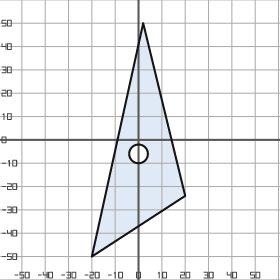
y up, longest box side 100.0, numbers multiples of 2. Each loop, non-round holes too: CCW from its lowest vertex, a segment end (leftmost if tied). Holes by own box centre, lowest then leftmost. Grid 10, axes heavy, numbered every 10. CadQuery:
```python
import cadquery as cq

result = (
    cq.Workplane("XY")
    .moveTo(-20.0, -50.0)
    .lineTo(20.0, -24.0)
    .lineTo(2.0, 50.0)
    .close()
    .moveTo(0.0, -6.0)
    .circle(4.0)
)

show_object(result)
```